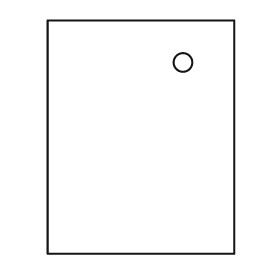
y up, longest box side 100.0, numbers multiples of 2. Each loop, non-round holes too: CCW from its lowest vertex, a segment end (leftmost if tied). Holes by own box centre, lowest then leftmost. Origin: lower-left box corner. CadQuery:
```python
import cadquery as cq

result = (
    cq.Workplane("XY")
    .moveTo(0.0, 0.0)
    .lineTo(80.0, 0.0)
    .lineTo(80.0, 100.0)
    .lineTo(0.0, 100.0)
    .close()
    .moveTo(58.0, 82.0)
    .circle(4.0)
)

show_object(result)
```